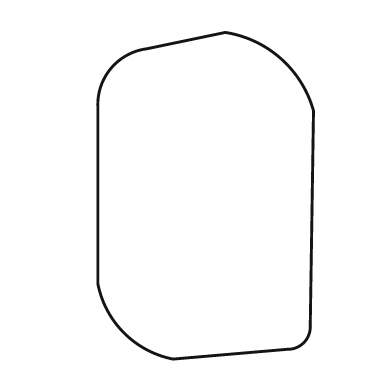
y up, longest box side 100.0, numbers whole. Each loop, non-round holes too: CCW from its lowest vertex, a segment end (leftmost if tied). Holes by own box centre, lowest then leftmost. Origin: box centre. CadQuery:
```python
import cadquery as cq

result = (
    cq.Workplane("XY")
    .moveTo(-10.0, -50.0)
    .lineTo(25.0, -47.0)
    .threePointArc((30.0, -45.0), (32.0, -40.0))
    .lineTo(33.0, 26.0)
    .threePointArc((23.0, 42.0), (6.0, 50.0))
    .lineTo(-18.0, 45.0)
    .threePointArc((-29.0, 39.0), (-33.0, 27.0))
    .lineTo(-33.0, -27.0)
    .threePointArc((-25.0, -42.0), (-10.0, -50.0))
    .close()
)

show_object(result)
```